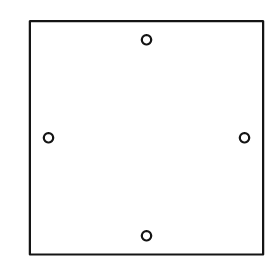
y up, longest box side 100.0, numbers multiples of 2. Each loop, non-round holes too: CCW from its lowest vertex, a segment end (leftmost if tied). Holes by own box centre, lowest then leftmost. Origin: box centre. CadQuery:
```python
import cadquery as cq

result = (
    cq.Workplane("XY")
    .moveTo(-50.0, -50.0)
    .lineTo(50.0, -50.0)
    .lineTo(50.0, 50.0)
    .lineTo(-50.0, 50.0)
    .close()
    .moveTo(0.0, -42.0)
    .circle(2.0)
    .moveTo(-42.0, 0.0)
    .circle(2.0)
    .moveTo(42.0, 0.0)
    .circle(2.0)
    .moveTo(0.0, 42.0)
    .circle(2.0)
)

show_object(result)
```